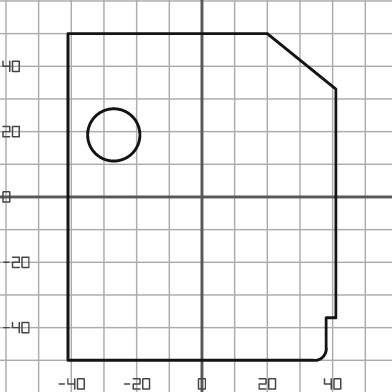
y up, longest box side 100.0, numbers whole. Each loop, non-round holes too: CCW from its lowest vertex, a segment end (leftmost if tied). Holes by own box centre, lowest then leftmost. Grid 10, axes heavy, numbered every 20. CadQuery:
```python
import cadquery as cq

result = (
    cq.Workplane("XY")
    .moveTo(-41.0, -50.0)
    .lineTo(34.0, -50.0)
    .threePointArc((37.0, -49.0), (38.0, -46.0))
    .lineTo(38.0, -37.0)
    .lineTo(41.0, -37.0)
    .lineTo(41.0, 33.0)
    .lineTo(20.0, 50.0)
    .lineTo(-41.0, 50.0)
    .close()
    .moveTo(-27.0, 19.0)
    .circle(8.0)
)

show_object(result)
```